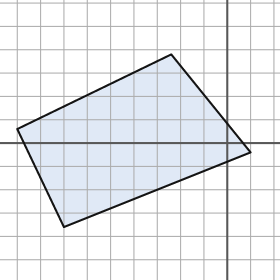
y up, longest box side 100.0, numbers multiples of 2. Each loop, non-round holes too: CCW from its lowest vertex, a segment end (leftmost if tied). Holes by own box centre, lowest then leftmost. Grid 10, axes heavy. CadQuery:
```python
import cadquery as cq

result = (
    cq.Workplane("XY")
    .moveTo(-70.0, -36.0)
    .lineTo(10.0, -4.0)
    .lineTo(-24.0, 38.0)
    .lineTo(-90.0, 6.0)
    .close()
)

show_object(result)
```